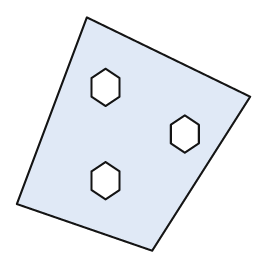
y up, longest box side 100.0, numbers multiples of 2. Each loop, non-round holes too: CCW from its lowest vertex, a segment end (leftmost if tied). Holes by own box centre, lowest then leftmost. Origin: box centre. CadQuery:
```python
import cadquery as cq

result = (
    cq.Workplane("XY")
    .moveTo(8.0, -50.0)
    .lineTo(50.0, 16.0)
    .lineTo(-20.0, 50.0)
    .lineTo(-50.0, -30.0)
    .close()
    .moveTo(-12.0, -28.0)
    .lineTo(-6.0, -24.0)
    .lineTo(-6.0, -16.0)
    .lineTo(-12.0, -12.0)
    .lineTo(-18.0, -16.0)
    .lineTo(-18.0, -24.0)
    .close()
    .moveTo(22.0, -8.0)
    .lineTo(28.0, -4.0)
    .lineTo(28.0, 4.0)
    .lineTo(22.0, 8.0)
    .lineTo(16.0, 4.0)
    .lineTo(16.0, -4.0)
    .close()
    .moveTo(-12.0, 12.0)
    .lineTo(-6.0, 16.0)
    .lineTo(-6.0, 24.0)
    .lineTo(-12.0, 28.0)
    .lineTo(-18.0, 24.0)
    .lineTo(-18.0, 16.0)
    .close()
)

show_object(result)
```